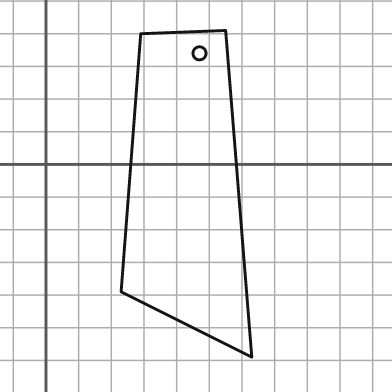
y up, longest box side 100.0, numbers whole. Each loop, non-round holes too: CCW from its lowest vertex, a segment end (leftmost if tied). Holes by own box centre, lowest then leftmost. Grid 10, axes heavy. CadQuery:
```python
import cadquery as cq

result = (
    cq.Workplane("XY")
    .moveTo(63.0, -59.0)
    .lineTo(55.0, 41.0)
    .lineTo(29.0, 40.0)
    .lineTo(23.0, -39.0)
    .close()
    .moveTo(47.0, 34.0)
    .circle(2.0)
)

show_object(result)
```